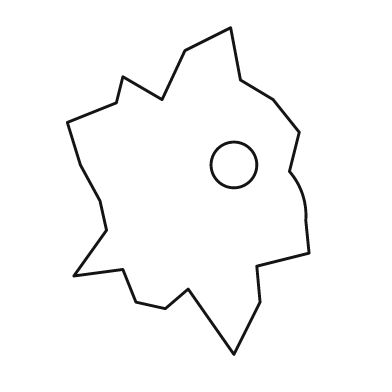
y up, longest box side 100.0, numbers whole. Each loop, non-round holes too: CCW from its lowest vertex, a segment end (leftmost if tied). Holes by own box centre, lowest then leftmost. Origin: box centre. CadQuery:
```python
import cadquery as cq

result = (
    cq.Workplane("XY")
    .moveTo(14.0, -50.0)
    .lineTo(22.0, -34.0)
    .lineTo(21.0, -23.0)
    .lineTo(37.0, -19.0)
    .lineTo(36.0, -9.0)
    .threePointArc((35.0, -1.0), (31.0, 6.0))
    .lineTo(34.0, 18.0)
    .lineTo(26.0, 28.0)
    .lineTo(16.0, 34.0)
    .lineTo(13.0, 50.0)
    .lineTo(-1.0, 43.0)
    .lineTo(-8.0, 28.0)
    .lineTo(-20.0, 35.0)
    .lineTo(-22.0, 27.0)
    .lineTo(-37.0, 21.0)
    .lineTo(-33.0, 8.0)
    .lineTo(-27.0, -3.0)
    .lineTo(-25.0, -12.0)
    .lineTo(-35.0, -26.0)
    .lineTo(-20.0, -24.0)
    .lineTo(-16.0, -34.0)
    .lineTo(-7.0, -36.0)
    .lineTo(0.0, -30.0)
    .close()
    .moveTo(14.0, 8.0)
    .circle(7.0)
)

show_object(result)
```